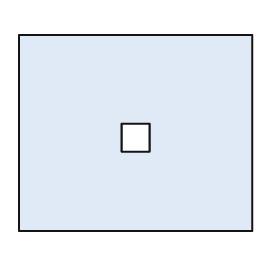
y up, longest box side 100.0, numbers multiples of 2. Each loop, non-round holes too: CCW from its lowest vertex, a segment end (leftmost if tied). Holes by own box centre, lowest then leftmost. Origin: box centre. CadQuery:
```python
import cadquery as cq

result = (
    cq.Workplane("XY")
    .moveTo(-50.0, -42.0)
    .lineTo(50.0, -42.0)
    .lineTo(50.0, 42.0)
    .lineTo(-50.0, 42.0)
    .close()
    .moveTo(-6.0, -8.0)
    .lineTo(6.0, -8.0)
    .lineTo(6.0, 4.0)
    .lineTo(-6.0, 4.0)
    .close()
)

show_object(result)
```